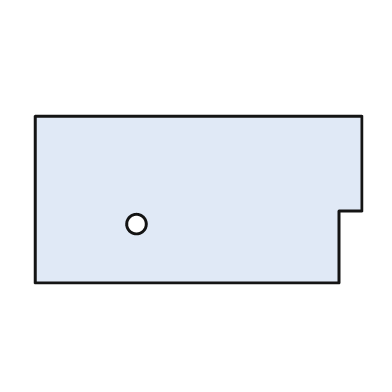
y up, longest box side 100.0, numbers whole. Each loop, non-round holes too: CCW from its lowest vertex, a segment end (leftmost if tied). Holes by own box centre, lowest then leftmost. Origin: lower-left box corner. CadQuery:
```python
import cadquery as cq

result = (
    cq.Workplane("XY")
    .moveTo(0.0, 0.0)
    .lineTo(93.0, 0.0)
    .lineTo(93.0, 22.0)
    .lineTo(100.0, 22.0)
    .lineTo(100.0, 51.0)
    .lineTo(0.0, 51.0)
    .close()
    .moveTo(31.0, 18.0)
    .circle(3.0)
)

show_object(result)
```